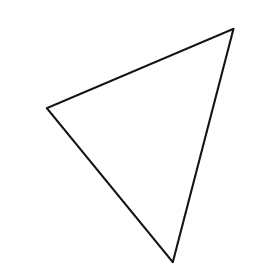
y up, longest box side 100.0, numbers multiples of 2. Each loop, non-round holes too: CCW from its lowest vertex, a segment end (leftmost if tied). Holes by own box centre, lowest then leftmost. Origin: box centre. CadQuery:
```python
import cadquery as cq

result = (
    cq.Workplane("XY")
    .moveTo(14.0, -50.0)
    .lineTo(40.0, 50.0)
    .lineTo(-40.0, 16.0)
    .close()
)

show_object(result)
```